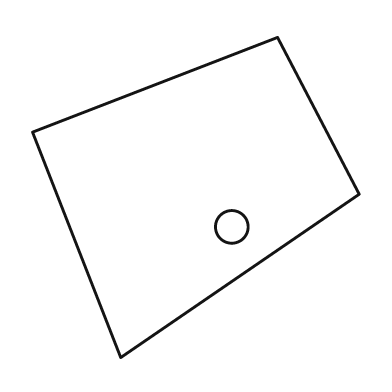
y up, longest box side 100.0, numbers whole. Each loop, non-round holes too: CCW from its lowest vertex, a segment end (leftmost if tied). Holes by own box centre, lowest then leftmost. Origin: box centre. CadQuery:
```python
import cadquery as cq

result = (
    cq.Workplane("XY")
    .moveTo(-23.0, -49.0)
    .lineTo(50.0, 1.0)
    .lineTo(25.0, 49.0)
    .lineTo(-50.0, 20.0)
    .close()
    .moveTo(11.0, -9.0)
    .circle(5.0)
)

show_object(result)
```